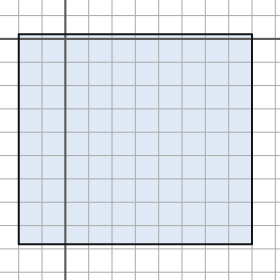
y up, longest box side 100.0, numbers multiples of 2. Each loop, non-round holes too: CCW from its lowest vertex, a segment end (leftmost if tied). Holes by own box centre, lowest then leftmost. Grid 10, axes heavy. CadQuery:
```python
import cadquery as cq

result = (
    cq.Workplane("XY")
    .moveTo(-20.0, -88.0)
    .lineTo(80.0, -88.0)
    .lineTo(80.0, 2.0)
    .lineTo(-20.0, 2.0)
    .close()
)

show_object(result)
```